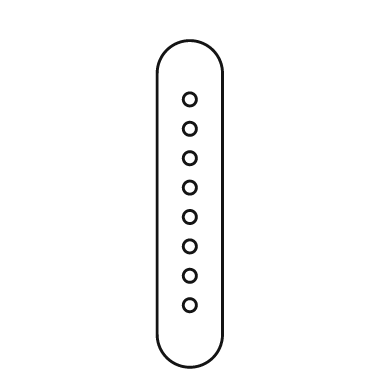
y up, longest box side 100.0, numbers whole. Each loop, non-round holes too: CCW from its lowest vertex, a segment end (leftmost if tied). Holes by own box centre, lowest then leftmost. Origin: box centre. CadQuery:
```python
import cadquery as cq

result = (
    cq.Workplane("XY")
    .moveTo(-10.0, -40.0)
    .threePointArc((0.0, -50.0), (10.0, -40.0))
    .lineTo(10.0, 40.0)
    .threePointArc((0.0, 50.0), (-10.0, 40.0))
    .close()
    .moveTo(0.0, -31.0)
    .circle(2.0)
    .moveTo(0.0, -22.0)
    .circle(2.0)
    .moveTo(0.0, -13.0)
    .circle(2.0)
    .moveTo(0.0, -4.0)
    .circle(2.0)
    .moveTo(0.0, 5.0)
    .circle(2.0)
    .moveTo(0.0, 14.0)
    .circle(2.0)
    .moveTo(0.0, 23.0)
    .circle(2.0)
    .moveTo(0.0, 32.0)
    .circle(2.0)
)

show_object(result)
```